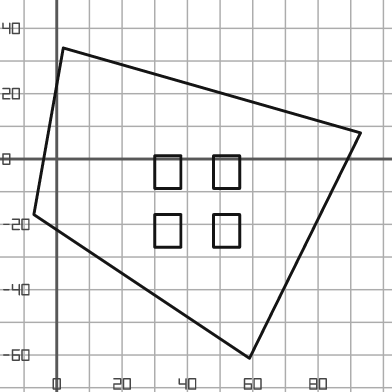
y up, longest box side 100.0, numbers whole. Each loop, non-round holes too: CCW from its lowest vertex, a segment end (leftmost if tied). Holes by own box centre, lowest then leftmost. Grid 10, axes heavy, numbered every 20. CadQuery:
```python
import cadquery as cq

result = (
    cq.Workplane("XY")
    .moveTo(59.0, -61.0)
    .lineTo(93.0, 8.0)
    .lineTo(2.0, 34.0)
    .lineTo(-7.0, -17.0)
    .close()
    .moveTo(30.0, -27.0)
    .lineTo(38.0, -27.0)
    .lineTo(38.0, -17.0)
    .lineTo(30.0, -17.0)
    .close()
    .moveTo(48.0, -27.0)
    .lineTo(56.0, -27.0)
    .lineTo(56.0, -17.0)
    .lineTo(48.0, -17.0)
    .close()
    .moveTo(30.0, -9.0)
    .lineTo(38.0, -9.0)
    .lineTo(38.0, 1.0)
    .lineTo(30.0, 1.0)
    .close()
    .moveTo(48.0, -9.0)
    .lineTo(56.0, -9.0)
    .lineTo(56.0, 1.0)
    .lineTo(48.0, 1.0)
    .close()
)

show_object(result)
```